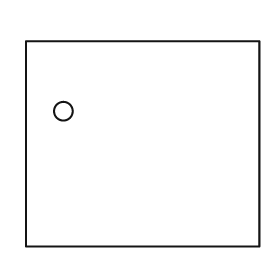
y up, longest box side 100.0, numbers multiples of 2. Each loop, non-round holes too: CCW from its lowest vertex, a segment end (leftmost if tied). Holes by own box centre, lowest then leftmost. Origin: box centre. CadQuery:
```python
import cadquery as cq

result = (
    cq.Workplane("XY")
    .moveTo(-50.0, -44.0)
    .lineTo(50.0, -44.0)
    .lineTo(50.0, 44.0)
    .lineTo(-50.0, 44.0)
    .close()
    .moveTo(-34.0, 14.0)
    .circle(4.0)
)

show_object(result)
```